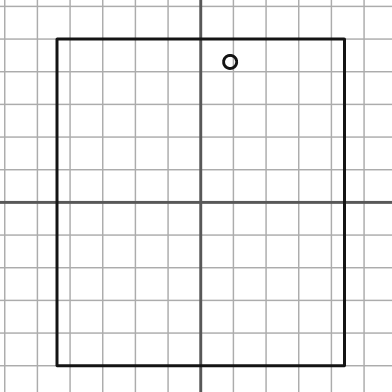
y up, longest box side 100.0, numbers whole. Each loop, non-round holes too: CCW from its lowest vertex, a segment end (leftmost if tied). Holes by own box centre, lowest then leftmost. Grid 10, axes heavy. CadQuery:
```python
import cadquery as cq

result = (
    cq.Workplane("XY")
    .moveTo(-44.0, -50.0)
    .lineTo(44.0, -50.0)
    .lineTo(44.0, 50.0)
    .lineTo(-44.0, 50.0)
    .close()
    .moveTo(9.0, 43.0)
    .circle(2.0)
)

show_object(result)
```